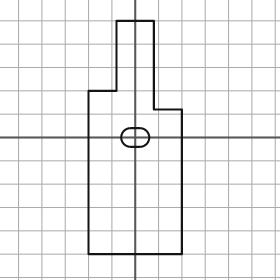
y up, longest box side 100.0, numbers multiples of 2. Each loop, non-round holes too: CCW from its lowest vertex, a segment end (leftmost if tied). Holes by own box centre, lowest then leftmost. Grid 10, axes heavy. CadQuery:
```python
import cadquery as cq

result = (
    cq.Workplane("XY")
    .moveTo(-20.0, -50.0)
    .lineTo(20.0, -50.0)
    .lineTo(20.0, 12.0)
    .lineTo(8.0, 12.0)
    .lineTo(8.0, 50.0)
    .lineTo(-8.0, 50.0)
    .lineTo(-8.0, 20.0)
    .lineTo(-20.0, 20.0)
    .close()
    .moveTo(-2.0, -4.0)
    .lineTo(2.0, -4.0)
    .threePointArc((6.0, 0.0), (2.0, 4.0))
    .lineTo(-2.0, 4.0)
    .threePointArc((-6.0, 0.0), (-2.0, -4.0))
    .close()
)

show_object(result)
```